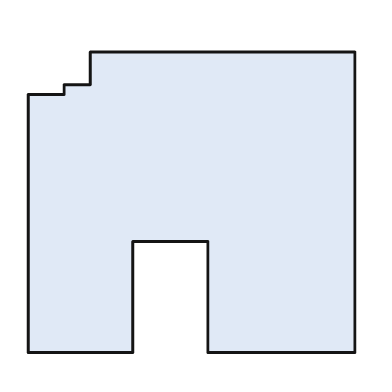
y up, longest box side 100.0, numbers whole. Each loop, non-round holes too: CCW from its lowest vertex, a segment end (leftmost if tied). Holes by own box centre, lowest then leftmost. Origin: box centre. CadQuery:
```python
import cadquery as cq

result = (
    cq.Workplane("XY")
    .moveTo(-50.0, -46.0)
    .lineTo(-18.0, -46.0)
    .lineTo(-18.0, -12.0)
    .lineTo(5.0, -12.0)
    .lineTo(5.0, -46.0)
    .lineTo(50.0, -46.0)
    .lineTo(50.0, 46.0)
    .lineTo(-31.0, 46.0)
    .lineTo(-31.0, 36.0)
    .lineTo(-39.0, 36.0)
    .lineTo(-39.0, 33.0)
    .lineTo(-50.0, 33.0)
    .close()
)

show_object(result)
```